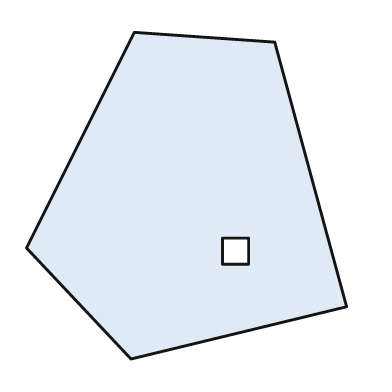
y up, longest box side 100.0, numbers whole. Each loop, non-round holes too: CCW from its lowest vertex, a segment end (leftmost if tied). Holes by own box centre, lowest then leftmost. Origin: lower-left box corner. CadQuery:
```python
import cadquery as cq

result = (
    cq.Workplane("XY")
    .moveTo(32.0, 0.0)
    .lineTo(98.0, 16.0)
    .lineTo(76.0, 97.0)
    .lineTo(33.0, 100.0)
    .lineTo(0.0, 34.0)
    .close()
    .moveTo(60.0, 29.0)
    .lineTo(68.0, 29.0)
    .lineTo(68.0, 37.0)
    .lineTo(60.0, 37.0)
    .close()
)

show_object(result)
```